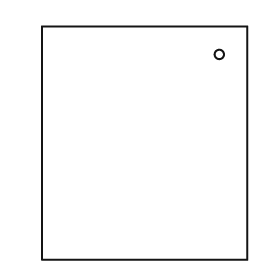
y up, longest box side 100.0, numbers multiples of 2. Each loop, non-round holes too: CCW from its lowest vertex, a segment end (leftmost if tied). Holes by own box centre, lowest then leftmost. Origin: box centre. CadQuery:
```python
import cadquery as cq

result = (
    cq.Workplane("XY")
    .moveTo(-44.0, -50.0)
    .lineTo(44.0, -50.0)
    .lineTo(44.0, 50.0)
    .lineTo(-44.0, 50.0)
    .close()
    .moveTo(32.0, 38.0)
    .circle(2.0)
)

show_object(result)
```